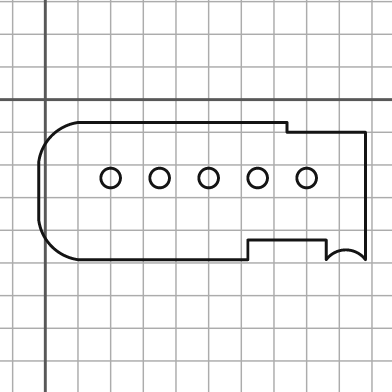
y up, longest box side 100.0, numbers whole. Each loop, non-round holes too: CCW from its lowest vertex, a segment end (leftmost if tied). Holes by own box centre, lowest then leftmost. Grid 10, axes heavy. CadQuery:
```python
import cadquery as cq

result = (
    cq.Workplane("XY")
    .moveTo(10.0, -49.0)
    .lineTo(62.0, -49.0)
    .lineTo(62.0, -43.0)
    .lineTo(86.0, -43.0)
    .lineTo(86.0, -49.0)
    .threePointArc((92.0, -46.0), (98.0, -49.0))
    .lineTo(98.0, -10.0)
    .lineTo(74.0, -10.0)
    .lineTo(74.0, -7.0)
    .lineTo(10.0, -7.0)
    .threePointArc((2.0, -11.0), (-2.0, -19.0))
    .lineTo(-2.0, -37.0)
    .threePointArc((2.0, -45.0), (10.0, -49.0))
    .close()
    .moveTo(20.0, -24.0)
    .circle(3.0)
    .moveTo(35.0, -24.0)
    .circle(3.0)
    .moveTo(50.0, -24.0)
    .circle(3.0)
    .moveTo(65.0, -24.0)
    .circle(3.0)
    .moveTo(80.0, -24.0)
    .circle(3.0)
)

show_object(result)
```